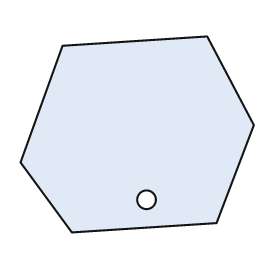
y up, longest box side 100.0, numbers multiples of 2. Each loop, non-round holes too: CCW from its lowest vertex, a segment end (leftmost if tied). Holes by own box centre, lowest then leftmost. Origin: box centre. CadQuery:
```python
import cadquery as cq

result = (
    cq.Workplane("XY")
    .moveTo(-28.0, -42.0)
    .lineTo(34.0, -38.0)
    .lineTo(50.0, 4.0)
    .lineTo(30.0, 42.0)
    .lineTo(-32.0, 38.0)
    .lineTo(-50.0, -12.0)
    .close()
    .moveTo(4.0, -28.0)
    .circle(4.0)
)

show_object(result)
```